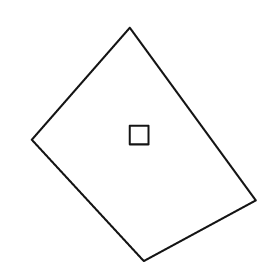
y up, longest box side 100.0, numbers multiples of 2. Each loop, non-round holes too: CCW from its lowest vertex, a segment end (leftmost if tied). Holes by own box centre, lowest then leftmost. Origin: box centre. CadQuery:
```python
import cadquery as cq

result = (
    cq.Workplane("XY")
    .moveTo(0.0, -50.0)
    .lineTo(48.0, -24.0)
    .lineTo(-6.0, 50.0)
    .lineTo(-48.0, 2.0)
    .close()
    .moveTo(-6.0, 0.0)
    .lineTo(2.0, 0.0)
    .lineTo(2.0, 8.0)
    .lineTo(-6.0, 8.0)
    .close()
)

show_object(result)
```